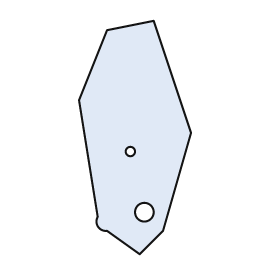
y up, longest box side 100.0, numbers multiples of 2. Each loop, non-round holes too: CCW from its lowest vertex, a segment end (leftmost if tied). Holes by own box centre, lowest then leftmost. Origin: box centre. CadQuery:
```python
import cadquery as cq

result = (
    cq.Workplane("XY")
    .moveTo(2.0, -50.0)
    .lineTo(12.0, -40.0)
    .lineTo(24.0, 2.0)
    .lineTo(8.0, 50.0)
    .lineTo(-12.0, 46.0)
    .lineTo(-24.0, 16.0)
    .lineTo(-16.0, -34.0)
    .threePointArc((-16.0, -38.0), (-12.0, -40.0))
    .close()
    .moveTo(4.0, -32.0)
    .circle(4.0)
    .moveTo(-2.0, -6.0)
    .circle(2.0)
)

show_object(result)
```